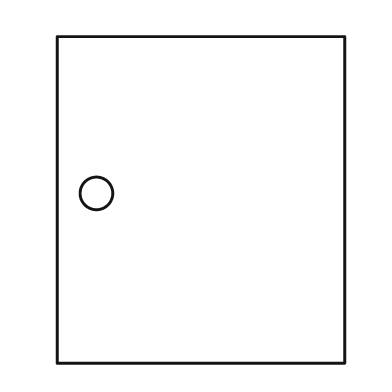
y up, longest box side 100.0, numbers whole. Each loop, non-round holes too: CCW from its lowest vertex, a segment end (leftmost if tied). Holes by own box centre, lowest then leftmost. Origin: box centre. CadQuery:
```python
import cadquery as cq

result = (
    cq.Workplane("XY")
    .moveTo(-44.0, -50.0)
    .lineTo(44.0, -50.0)
    .lineTo(44.0, 50.0)
    .lineTo(-44.0, 50.0)
    .close()
    .moveTo(-32.0, 2.0)
    .circle(5.0)
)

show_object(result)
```